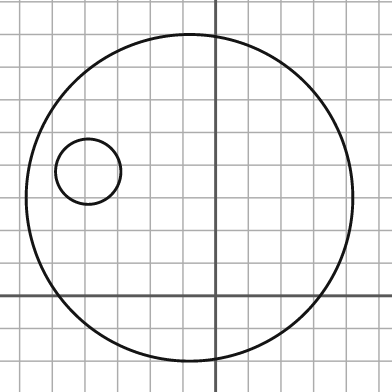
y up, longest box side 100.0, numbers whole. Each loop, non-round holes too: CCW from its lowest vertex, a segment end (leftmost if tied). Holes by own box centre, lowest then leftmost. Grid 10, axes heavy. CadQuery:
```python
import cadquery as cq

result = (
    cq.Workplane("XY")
    .moveTo(-8.0, 30.0)
    .circle(50.0)
    .moveTo(-39.0, 38.0)
    .circle(10.0)
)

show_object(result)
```